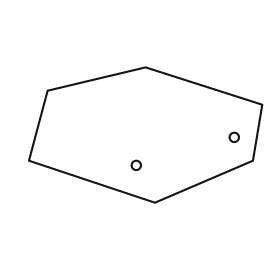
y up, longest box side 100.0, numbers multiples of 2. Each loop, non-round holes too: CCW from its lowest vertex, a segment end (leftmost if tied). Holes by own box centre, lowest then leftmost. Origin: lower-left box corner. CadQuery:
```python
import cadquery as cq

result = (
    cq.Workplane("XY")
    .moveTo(54.0, 0.0)
    .lineTo(96.0, 18.0)
    .lineTo(100.0, 42.0)
    .lineTo(50.0, 58.0)
    .lineTo(8.0, 48.0)
    .lineTo(0.0, 18.0)
    .close()
    .moveTo(46.0, 16.0)
    .circle(2.0)
    .moveTo(88.0, 28.0)
    .circle(2.0)
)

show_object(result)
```